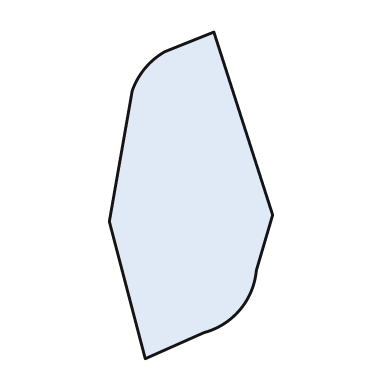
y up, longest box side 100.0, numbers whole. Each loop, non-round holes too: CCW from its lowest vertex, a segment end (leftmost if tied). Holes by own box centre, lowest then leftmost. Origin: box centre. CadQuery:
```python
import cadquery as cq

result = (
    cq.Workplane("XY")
    .moveTo(-14.0, -50.0)
    .lineTo(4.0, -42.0)
    .threePointArc((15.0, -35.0), (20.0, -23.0))
    .lineTo(25.0, -6.0)
    .lineTo(7.0, 50.0)
    .lineTo(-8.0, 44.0)
    .threePointArc((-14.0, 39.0), (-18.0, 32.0))
    .lineTo(-25.0, -8.0)
    .close()
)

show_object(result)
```